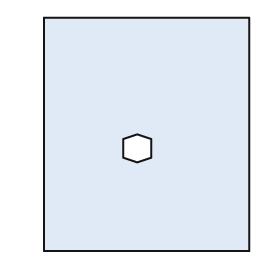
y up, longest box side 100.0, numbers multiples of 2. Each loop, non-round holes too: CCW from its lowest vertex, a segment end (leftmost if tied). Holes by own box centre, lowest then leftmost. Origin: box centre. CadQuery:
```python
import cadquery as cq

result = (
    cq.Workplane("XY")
    .moveTo(-44.0, -50.0)
    .lineTo(44.0, -50.0)
    .lineTo(44.0, 50.0)
    .lineTo(-44.0, 50.0)
    .close()
    .moveTo(-4.0, -12.0)
    .lineTo(2.0, -10.0)
    .lineTo(2.0, -2.0)
    .lineTo(-4.0, 0.0)
    .lineTo(-10.0, -2.0)
    .lineTo(-10.0, -10.0)
    .close()
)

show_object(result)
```